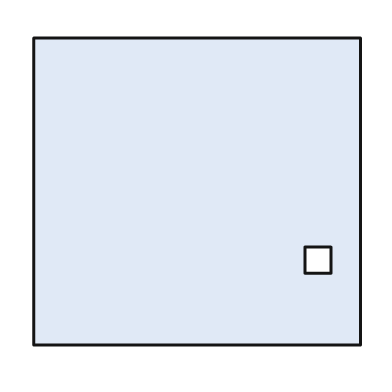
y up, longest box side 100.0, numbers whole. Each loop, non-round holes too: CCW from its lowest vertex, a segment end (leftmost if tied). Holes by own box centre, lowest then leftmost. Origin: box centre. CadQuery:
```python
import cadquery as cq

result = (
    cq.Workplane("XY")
    .moveTo(-50.0, -47.0)
    .lineTo(50.0, -47.0)
    .lineTo(50.0, 47.0)
    .lineTo(-50.0, 47.0)
    .close()
    .moveTo(33.0, -25.0)
    .lineTo(41.0, -25.0)
    .lineTo(41.0, -17.0)
    .lineTo(33.0, -17.0)
    .close()
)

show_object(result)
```